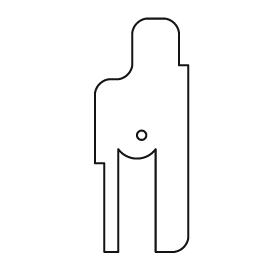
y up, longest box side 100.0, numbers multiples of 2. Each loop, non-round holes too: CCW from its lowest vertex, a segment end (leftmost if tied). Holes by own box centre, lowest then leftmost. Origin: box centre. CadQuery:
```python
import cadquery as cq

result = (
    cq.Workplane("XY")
    .moveTo(-16.0, -50.0)
    .lineTo(-10.0, -50.0)
    .lineTo(-10.0, -6.0)
    .threePointArc((-2.0, -10.0), (6.0, -6.0))
    .lineTo(6.0, -50.0)
    .lineTo(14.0, -50.0)
    .threePointArc((18.0, -48.0), (20.0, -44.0))
    .lineTo(20.0, 30.0)
    .lineTo(16.0, 30.0)
    .lineTo(16.0, 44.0)
    .threePointArc((14.0, 48.0), (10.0, 50.0))
    .lineTo(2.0, 50.0)
    .threePointArc((-2.0, 48.0), (-4.0, 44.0))
    .lineTo(-4.0, 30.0)
    .threePointArc((-6.0, 26.0), (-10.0, 24.0))
    .lineTo(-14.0, 24.0)
    .threePointArc((-18.0, 22.0), (-20.0, 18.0))
    .lineTo(-20.0, -12.0)
    .lineTo(-16.0, -12.0)
    .close()
    .moveTo(0.0, 0.0)
    .circle(2.0)
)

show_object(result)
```